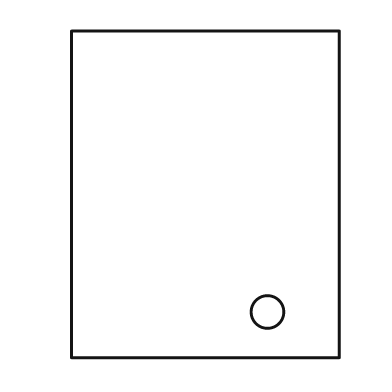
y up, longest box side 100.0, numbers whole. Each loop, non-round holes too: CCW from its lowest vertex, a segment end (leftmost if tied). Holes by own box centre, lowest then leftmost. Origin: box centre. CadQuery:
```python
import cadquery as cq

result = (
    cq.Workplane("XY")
    .moveTo(-41.0, -50.0)
    .lineTo(41.0, -50.0)
    .lineTo(41.0, 50.0)
    .lineTo(-41.0, 50.0)
    .close()
    .moveTo(19.0, -36.0)
    .circle(5.0)
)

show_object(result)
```